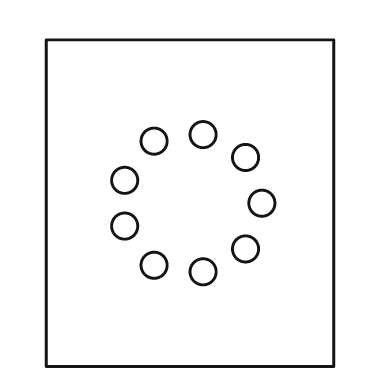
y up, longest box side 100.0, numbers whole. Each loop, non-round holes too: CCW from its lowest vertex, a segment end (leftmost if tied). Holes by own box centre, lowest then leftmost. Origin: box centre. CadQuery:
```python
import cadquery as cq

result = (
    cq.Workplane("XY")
    .moveTo(-44.0, -50.0)
    .lineTo(44.0, -50.0)
    .lineTo(44.0, 50.0)
    .lineTo(-44.0, 50.0)
    .close()
    .moveTo(4.0, -21.0)
    .circle(4.0)
    .moveTo(-11.0, -19.0)
    .circle(4.0)
    .moveTo(17.0, -14.0)
    .circle(4.0)
    .moveTo(-20.0, -7.0)
    .circle(4.0)
    .moveTo(22.0, 0.0)
    .circle(4.0)
    .moveTo(-20.0, 7.0)
    .circle(4.0)
    .moveTo(17.0, 14.0)
    .circle(4.0)
    .moveTo(-11.0, 19.0)
    .circle(4.0)
    .moveTo(4.0, 21.0)
    .circle(4.0)
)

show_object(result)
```